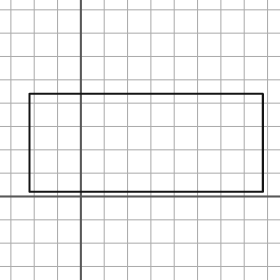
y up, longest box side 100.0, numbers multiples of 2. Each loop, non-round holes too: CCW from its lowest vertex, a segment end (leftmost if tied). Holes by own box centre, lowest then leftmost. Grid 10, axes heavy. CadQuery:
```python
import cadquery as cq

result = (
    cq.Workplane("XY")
    .moveTo(-22.0, 2.0)
    .lineTo(78.0, 2.0)
    .lineTo(78.0, 44.0)
    .lineTo(-22.0, 44.0)
    .close()
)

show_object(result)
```